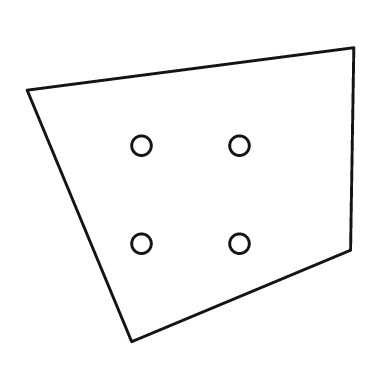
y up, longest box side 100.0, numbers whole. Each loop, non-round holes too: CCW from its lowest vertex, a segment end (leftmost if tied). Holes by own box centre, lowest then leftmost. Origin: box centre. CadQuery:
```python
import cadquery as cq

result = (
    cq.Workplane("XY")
    .moveTo(-18.0, -45.0)
    .lineTo(49.0, -17.0)
    .lineTo(50.0, 45.0)
    .lineTo(-50.0, 32.0)
    .close()
    .moveTo(-15.0, -15.0)
    .circle(3.0)
    .moveTo(15.0, -15.0)
    .circle(3.0)
    .moveTo(-15.0, 15.0)
    .circle(3.0)
    .moveTo(15.0, 15.0)
    .circle(3.0)
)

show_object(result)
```